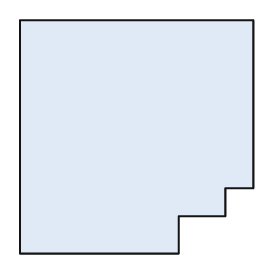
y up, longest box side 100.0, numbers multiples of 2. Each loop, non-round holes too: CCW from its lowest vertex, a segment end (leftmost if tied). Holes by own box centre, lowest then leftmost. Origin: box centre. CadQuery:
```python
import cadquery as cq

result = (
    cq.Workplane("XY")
    .moveTo(-50.0, -50.0)
    .lineTo(18.0, -50.0)
    .lineTo(18.0, -34.0)
    .lineTo(38.0, -34.0)
    .lineTo(38.0, -22.0)
    .lineTo(50.0, -22.0)
    .lineTo(50.0, 50.0)
    .lineTo(-50.0, 50.0)
    .close()
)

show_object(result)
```